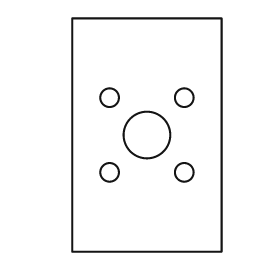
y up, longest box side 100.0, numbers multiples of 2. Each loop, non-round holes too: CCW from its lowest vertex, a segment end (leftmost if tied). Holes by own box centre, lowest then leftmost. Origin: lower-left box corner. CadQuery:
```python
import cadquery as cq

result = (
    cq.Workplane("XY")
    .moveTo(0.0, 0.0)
    .lineTo(64.0, 0.0)
    .lineTo(64.0, 100.0)
    .lineTo(0.0, 100.0)
    .close()
    .moveTo(16.0, 34.0)
    .circle(4.0)
    .moveTo(48.0, 34.0)
    .circle(4.0)
    .moveTo(32.0, 50.0)
    .circle(10.0)
    .moveTo(16.0, 66.0)
    .circle(4.0)
    .moveTo(48.0, 66.0)
    .circle(4.0)
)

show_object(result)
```